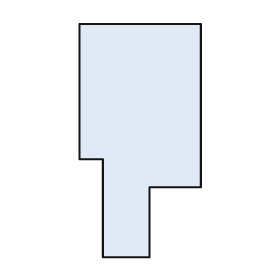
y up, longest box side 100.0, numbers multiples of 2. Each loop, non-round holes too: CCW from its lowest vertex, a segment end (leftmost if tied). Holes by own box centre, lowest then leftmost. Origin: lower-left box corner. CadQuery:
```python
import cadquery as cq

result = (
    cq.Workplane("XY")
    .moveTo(10.0, 0.0)
    .lineTo(30.0, 0.0)
    .lineTo(30.0, 30.0)
    .lineTo(52.0, 30.0)
    .lineTo(52.0, 100.0)
    .lineTo(0.0, 100.0)
    .lineTo(0.0, 42.0)
    .lineTo(10.0, 42.0)
    .close()
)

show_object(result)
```